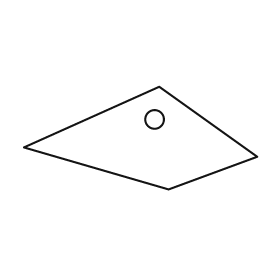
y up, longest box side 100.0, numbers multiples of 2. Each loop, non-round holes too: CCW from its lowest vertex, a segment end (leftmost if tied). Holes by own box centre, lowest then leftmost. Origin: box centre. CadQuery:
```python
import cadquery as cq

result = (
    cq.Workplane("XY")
    .moveTo(12.0, -22.0)
    .lineTo(50.0, -8.0)
    .lineTo(8.0, 22.0)
    .lineTo(-50.0, -4.0)
    .close()
    .moveTo(6.0, 8.0)
    .circle(4.0)
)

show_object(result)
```